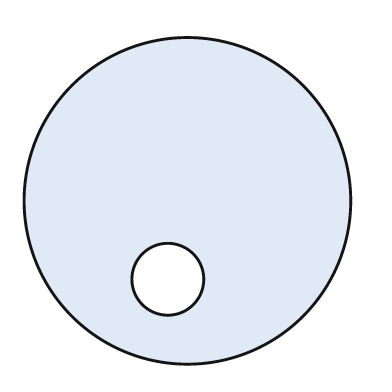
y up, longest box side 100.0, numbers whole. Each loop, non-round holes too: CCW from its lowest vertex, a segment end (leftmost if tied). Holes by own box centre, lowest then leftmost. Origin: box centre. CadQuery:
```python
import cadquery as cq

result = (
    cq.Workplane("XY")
    .moveTo(0.0, 0.0)
    .circle(50.0)
    .moveTo(-6.0, -24.0)
    .circle(11.0)
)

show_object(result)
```